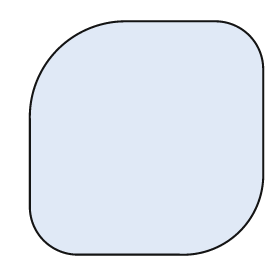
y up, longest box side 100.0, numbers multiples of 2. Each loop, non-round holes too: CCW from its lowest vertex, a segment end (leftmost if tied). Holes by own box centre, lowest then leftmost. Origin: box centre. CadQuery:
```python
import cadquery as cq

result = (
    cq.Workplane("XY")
    .moveTo(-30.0, -50.0)
    .lineTo(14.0, -50.0)
    .threePointArc((40.0, -40.0), (50.0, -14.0))
    .lineTo(50.0, 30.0)
    .threePointArc((44.0, 44.0), (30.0, 50.0))
    .lineTo(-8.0, 50.0)
    .threePointArc((-38.0, 38.0), (-50.0, 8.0))
    .lineTo(-50.0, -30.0)
    .threePointArc((-44.0, -44.0), (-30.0, -50.0))
    .close()
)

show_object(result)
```